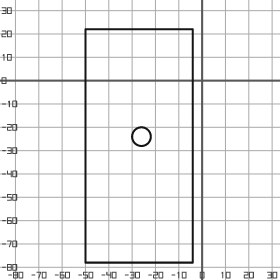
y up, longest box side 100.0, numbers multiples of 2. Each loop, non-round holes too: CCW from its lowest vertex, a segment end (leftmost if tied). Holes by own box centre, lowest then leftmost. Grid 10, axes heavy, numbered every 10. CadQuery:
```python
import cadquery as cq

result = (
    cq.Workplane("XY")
    .moveTo(-50.0, -78.0)
    .lineTo(-4.0, -78.0)
    .lineTo(-4.0, 22.0)
    .lineTo(-50.0, 22.0)
    .close()
    .moveTo(-26.0, -24.0)
    .circle(4.0)
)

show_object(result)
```